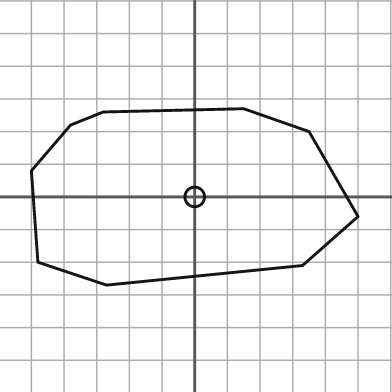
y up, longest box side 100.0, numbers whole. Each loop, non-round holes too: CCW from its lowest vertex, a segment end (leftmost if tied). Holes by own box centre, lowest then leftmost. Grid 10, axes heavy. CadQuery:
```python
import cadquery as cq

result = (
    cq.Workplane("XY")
    .moveTo(-27.0, -27.0)
    .lineTo(33.0, -21.0)
    .lineTo(50.0, -6.0)
    .lineTo(35.0, 20.0)
    .lineTo(15.0, 27.0)
    .lineTo(-28.0, 26.0)
    .lineTo(-38.0, 22.0)
    .lineTo(-50.0, 8.0)
    .lineTo(-48.0, -20.0)
    .close()
    .moveTo(0.0, 0.0)
    .circle(3.0)
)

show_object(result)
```